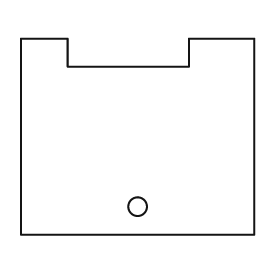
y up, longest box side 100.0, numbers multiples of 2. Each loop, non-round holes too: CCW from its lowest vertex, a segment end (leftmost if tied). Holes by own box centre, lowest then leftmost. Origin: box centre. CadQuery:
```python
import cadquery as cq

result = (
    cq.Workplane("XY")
    .moveTo(-50.0, -42.0)
    .lineTo(50.0, -42.0)
    .lineTo(50.0, 42.0)
    .lineTo(22.0, 42.0)
    .lineTo(22.0, 30.0)
    .lineTo(-30.0, 30.0)
    .lineTo(-30.0, 42.0)
    .lineTo(-50.0, 42.0)
    .close()
    .moveTo(0.0, -30.0)
    .circle(4.0)
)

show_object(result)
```